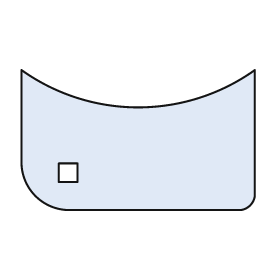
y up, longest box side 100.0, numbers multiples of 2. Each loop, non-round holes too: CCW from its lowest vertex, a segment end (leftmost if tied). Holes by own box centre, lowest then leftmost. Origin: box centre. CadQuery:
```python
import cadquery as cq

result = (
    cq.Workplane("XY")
    .moveTo(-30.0, -30.0)
    .lineTo(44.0, -30.0)
    .threePointArc((48.0, -28.0), (50.0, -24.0))
    .lineTo(50.0, 30.0)
    .threePointArc((0.0, 14.0), (-50.0, 30.0))
    .lineTo(-50.0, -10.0)
    .threePointArc((-44.0, -24.0), (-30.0, -30.0))
    .close()
    .moveTo(-34.0, -18.0)
    .lineTo(-26.0, -18.0)
    .lineTo(-26.0, -10.0)
    .lineTo(-34.0, -10.0)
    .close()
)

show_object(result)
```